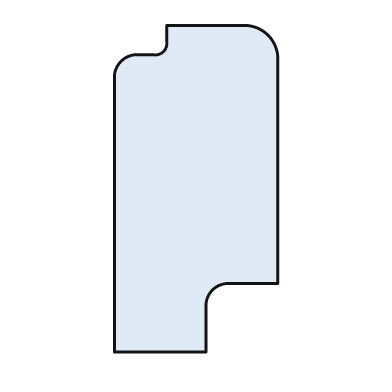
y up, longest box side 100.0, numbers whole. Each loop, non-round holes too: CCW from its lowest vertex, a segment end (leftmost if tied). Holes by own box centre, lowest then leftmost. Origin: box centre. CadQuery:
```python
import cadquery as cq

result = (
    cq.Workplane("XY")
    .moveTo(-25.0, -50.0)
    .lineTo(3.0, -50.0)
    .lineTo(3.0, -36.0)
    .threePointArc((5.0, -31.0), (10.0, -29.0))
    .lineTo(25.0, -29.0)
    .lineTo(25.0, 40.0)
    .threePointArc((22.0, 47.0), (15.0, 50.0))
    .lineTo(-9.0, 50.0)
    .lineTo(-9.0, 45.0)
    .threePointArc((-10.0, 42.0), (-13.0, 41.0))
    .lineTo(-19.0, 41.0)
    .threePointArc((-23.0, 39.0), (-25.0, 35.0))
    .close()
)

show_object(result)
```